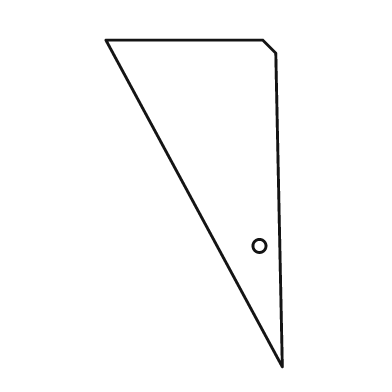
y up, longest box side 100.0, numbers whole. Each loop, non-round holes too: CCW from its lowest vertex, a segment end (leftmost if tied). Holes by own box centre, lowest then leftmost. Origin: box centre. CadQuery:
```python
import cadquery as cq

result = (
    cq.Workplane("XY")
    .moveTo(27.0, -50.0)
    .lineTo(25.0, 46.0)
    .lineTo(21.0, 50.0)
    .lineTo(-27.0, 50.0)
    .close()
    .moveTo(20.0, -13.0)
    .circle(2.0)
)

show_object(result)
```